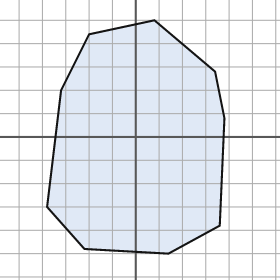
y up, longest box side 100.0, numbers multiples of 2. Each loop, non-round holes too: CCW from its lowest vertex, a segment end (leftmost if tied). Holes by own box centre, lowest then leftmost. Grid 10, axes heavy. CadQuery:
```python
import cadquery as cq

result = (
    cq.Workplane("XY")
    .moveTo(14.0, -50.0)
    .lineTo(36.0, -38.0)
    .lineTo(38.0, 8.0)
    .lineTo(34.0, 28.0)
    .lineTo(8.0, 50.0)
    .lineTo(-20.0, 44.0)
    .lineTo(-32.0, 20.0)
    .lineTo(-38.0, -30.0)
    .lineTo(-22.0, -48.0)
    .close()
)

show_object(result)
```